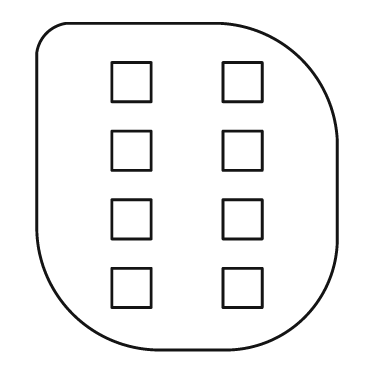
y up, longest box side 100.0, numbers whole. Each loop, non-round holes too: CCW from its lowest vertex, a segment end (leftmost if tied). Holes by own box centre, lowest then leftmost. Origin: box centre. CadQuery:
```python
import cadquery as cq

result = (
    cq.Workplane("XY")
    .moveTo(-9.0, -50.0)
    .lineTo(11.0, -50.0)
    .threePointArc((36.0, -40.0), (46.0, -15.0))
    .lineTo(46.0, 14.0)
    .threePointArc((35.0, 39.0), (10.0, 50.0))
    .lineTo(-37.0, 50.0)
    .threePointArc((-43.0, 47.0), (-46.0, 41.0))
    .lineTo(-46.0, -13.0)
    .threePointArc((-35.0, -39.0), (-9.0, -50.0))
    .close()
    .moveTo(-23.0, -37.0)
    .lineTo(-11.0, -37.0)
    .lineTo(-11.0, -25.0)
    .lineTo(-23.0, -25.0)
    .close()
    .moveTo(11.0, -37.0)
    .lineTo(23.0, -37.0)
    .lineTo(23.0, -25.0)
    .lineTo(11.0, -25.0)
    .close()
    .moveTo(-23.0, -16.0)
    .lineTo(-11.0, -16.0)
    .lineTo(-11.0, -4.0)
    .lineTo(-23.0, -4.0)
    .close()
    .moveTo(11.0, -16.0)
    .lineTo(23.0, -16.0)
    .lineTo(23.0, -4.0)
    .lineTo(11.0, -4.0)
    .close()
    .moveTo(-23.0, 5.0)
    .lineTo(-11.0, 5.0)
    .lineTo(-11.0, 17.0)
    .lineTo(-23.0, 17.0)
    .close()
    .moveTo(11.0, 5.0)
    .lineTo(23.0, 5.0)
    .lineTo(23.0, 17.0)
    .lineTo(11.0, 17.0)
    .close()
    .moveTo(-23.0, 26.0)
    .lineTo(-11.0, 26.0)
    .lineTo(-11.0, 38.0)
    .lineTo(-23.0, 38.0)
    .close()
    .moveTo(11.0, 26.0)
    .lineTo(23.0, 26.0)
    .lineTo(23.0, 38.0)
    .lineTo(11.0, 38.0)
    .close()
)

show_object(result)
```